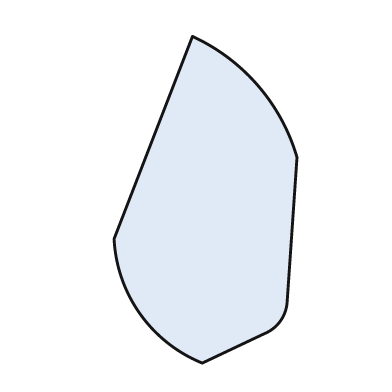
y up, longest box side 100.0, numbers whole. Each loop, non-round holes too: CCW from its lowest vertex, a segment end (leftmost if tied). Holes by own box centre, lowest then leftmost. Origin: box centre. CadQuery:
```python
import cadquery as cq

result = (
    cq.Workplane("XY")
    .moveTo(-1.0, -50.0)
    .lineTo(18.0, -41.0)
    .threePointArc((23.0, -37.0), (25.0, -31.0))
    .lineTo(28.0, 13.0)
    .threePointArc((16.0, 35.0), (-4.0, 50.0))
    .lineTo(-28.0, -12.0)
    .threePointArc((-20.0, -35.0), (-1.0, -50.0))
    .close()
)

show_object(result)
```